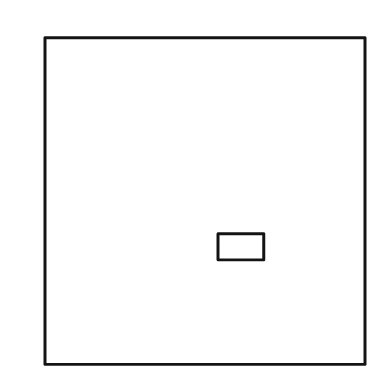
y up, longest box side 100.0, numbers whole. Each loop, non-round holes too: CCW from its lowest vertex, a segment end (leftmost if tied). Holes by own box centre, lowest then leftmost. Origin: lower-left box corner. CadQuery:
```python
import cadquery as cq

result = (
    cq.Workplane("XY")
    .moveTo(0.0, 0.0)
    .lineTo(98.0, 0.0)
    .lineTo(98.0, 100.0)
    .lineTo(0.0, 100.0)
    .close()
    .moveTo(53.0, 32.0)
    .lineTo(67.0, 32.0)
    .lineTo(67.0, 40.0)
    .lineTo(53.0, 40.0)
    .close()
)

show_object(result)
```